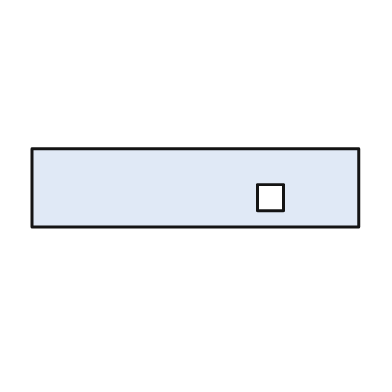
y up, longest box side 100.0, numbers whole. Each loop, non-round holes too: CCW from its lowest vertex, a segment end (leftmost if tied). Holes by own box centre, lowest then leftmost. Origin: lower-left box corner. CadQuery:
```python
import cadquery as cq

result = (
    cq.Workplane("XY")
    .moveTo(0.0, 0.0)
    .lineTo(100.0, 0.0)
    .lineTo(100.0, 24.0)
    .lineTo(0.0, 24.0)
    .close()
    .moveTo(69.0, 5.0)
    .lineTo(77.0, 5.0)
    .lineTo(77.0, 13.0)
    .lineTo(69.0, 13.0)
    .close()
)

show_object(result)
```